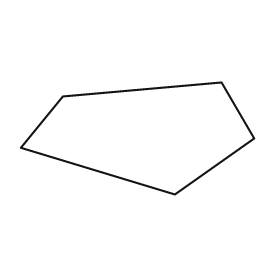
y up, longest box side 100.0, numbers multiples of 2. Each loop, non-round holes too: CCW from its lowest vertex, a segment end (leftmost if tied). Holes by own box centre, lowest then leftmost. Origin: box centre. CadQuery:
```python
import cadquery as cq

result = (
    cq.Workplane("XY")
    .moveTo(16.0, -24.0)
    .lineTo(50.0, 0.0)
    .lineTo(36.0, 24.0)
    .lineTo(-32.0, 18.0)
    .lineTo(-50.0, -4.0)
    .close()
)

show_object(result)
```